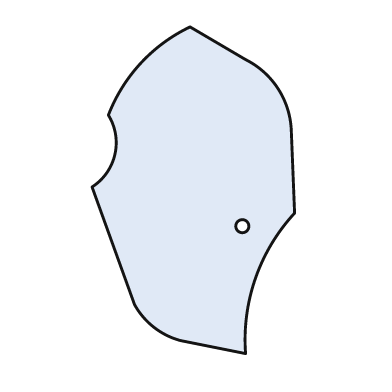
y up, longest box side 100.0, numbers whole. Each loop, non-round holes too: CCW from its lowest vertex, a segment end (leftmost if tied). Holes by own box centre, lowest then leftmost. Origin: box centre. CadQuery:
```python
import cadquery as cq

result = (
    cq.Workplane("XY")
    .moveTo(16.0, -50.0)
    .threePointArc((19.0, -27.0), (31.0, -7.0))
    .lineTo(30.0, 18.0)
    .threePointArc((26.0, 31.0), (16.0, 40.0))
    .lineTo(-1.0, 50.0)
    .threePointArc((-16.0, 39.0), (-26.0, 23.0))
    .threePointArc((-24.0, 11.0), (-31.0, 1.0))
    .lineTo(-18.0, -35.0)
    .threePointArc((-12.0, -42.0), (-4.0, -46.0))
    .close()
    .moveTo(15.0, -11.0)
    .circle(2.0)
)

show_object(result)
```